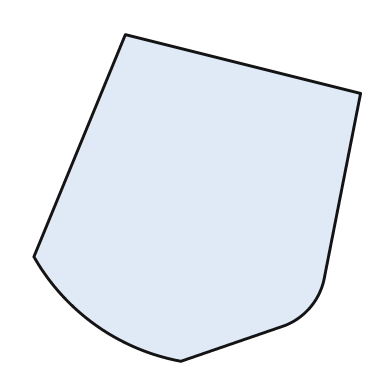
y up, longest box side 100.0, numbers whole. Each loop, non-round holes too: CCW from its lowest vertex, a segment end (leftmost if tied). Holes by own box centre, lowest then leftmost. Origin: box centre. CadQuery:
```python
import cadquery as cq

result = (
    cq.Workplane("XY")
    .moveTo(-5.0, -50.0)
    .lineTo(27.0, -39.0)
    .threePointArc((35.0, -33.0), (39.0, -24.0))
    .lineTo(50.0, 32.0)
    .lineTo(-22.0, 50.0)
    .lineTo(-50.0, -18.0)
    .threePointArc((-31.0, -39.0), (-5.0, -50.0))
    .close()
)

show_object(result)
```